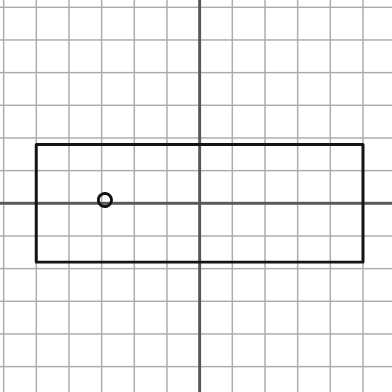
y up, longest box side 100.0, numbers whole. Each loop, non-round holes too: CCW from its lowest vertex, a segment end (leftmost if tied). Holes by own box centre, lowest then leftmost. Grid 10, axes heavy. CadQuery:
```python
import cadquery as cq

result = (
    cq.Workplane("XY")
    .moveTo(-50.0, -18.0)
    .lineTo(50.0, -18.0)
    .lineTo(50.0, 18.0)
    .lineTo(-50.0, 18.0)
    .close()
    .moveTo(-29.0, 1.0)
    .circle(2.0)
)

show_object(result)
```